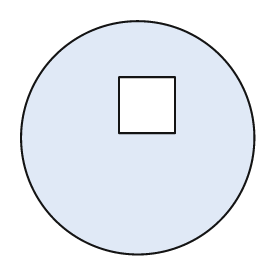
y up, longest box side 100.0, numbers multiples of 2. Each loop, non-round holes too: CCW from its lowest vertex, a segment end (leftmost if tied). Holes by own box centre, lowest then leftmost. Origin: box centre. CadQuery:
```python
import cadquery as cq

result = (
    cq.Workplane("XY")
    .moveTo(0.0, 0.0)
    .circle(50.0)
    .moveTo(-8.0, 2.0)
    .lineTo(16.0, 2.0)
    .lineTo(16.0, 26.0)
    .lineTo(-8.0, 26.0)
    .close()
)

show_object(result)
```